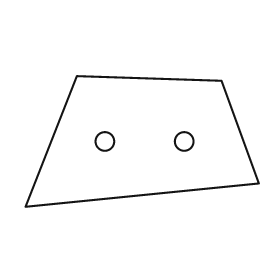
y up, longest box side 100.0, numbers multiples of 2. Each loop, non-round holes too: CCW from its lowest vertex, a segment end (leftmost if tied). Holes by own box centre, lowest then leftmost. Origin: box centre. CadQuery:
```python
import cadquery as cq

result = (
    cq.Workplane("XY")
    .moveTo(-50.0, -28.0)
    .lineTo(50.0, -18.0)
    .lineTo(34.0, 26.0)
    .lineTo(-28.0, 28.0)
    .close()
    .moveTo(-16.0, 0.0)
    .circle(4.0)
    .moveTo(18.0, 0.0)
    .circle(4.0)
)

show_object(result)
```